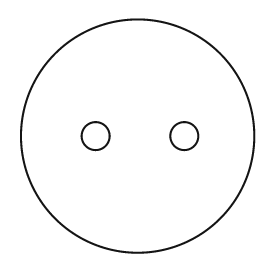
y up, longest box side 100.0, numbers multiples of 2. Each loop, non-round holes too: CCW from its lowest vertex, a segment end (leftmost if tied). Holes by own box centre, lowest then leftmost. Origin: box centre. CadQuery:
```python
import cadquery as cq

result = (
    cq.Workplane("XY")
    .moveTo(0.0, 0.0)
    .circle(50.0)
    .moveTo(-18.0, 0.0)
    .circle(6.0)
    .moveTo(20.0, 0.0)
    .circle(6.0)
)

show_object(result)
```